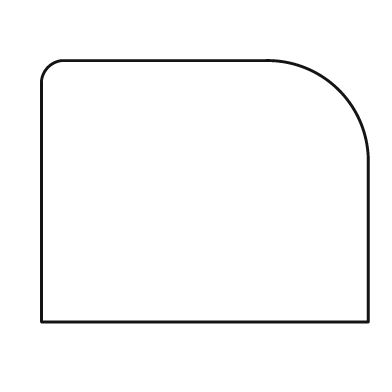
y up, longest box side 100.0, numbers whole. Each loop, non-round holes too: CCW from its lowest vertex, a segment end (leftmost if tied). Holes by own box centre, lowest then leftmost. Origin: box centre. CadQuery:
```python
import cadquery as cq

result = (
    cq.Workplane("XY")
    .moveTo(-50.0, -40.0)
    .lineTo(50.0, -40.0)
    .lineTo(50.0, 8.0)
    .threePointArc((41.0, 31.0), (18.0, 40.0))
    .lineTo(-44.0, 40.0)
    .threePointArc((-48.0, 38.0), (-50.0, 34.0))
    .close()
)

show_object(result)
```